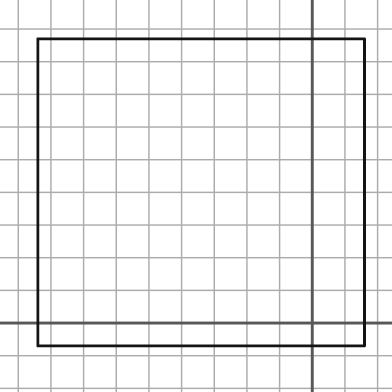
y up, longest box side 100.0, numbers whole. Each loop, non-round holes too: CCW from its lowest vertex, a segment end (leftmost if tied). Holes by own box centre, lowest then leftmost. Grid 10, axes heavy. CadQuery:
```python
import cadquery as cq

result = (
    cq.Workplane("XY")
    .moveTo(-84.0, -7.0)
    .lineTo(16.0, -7.0)
    .lineTo(16.0, 87.0)
    .lineTo(-84.0, 87.0)
    .close()
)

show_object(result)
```